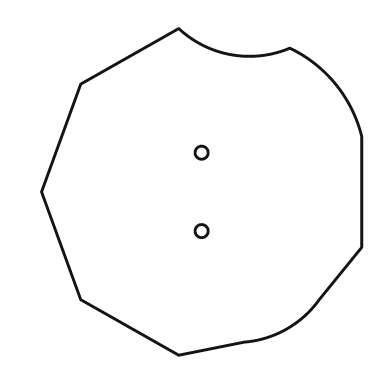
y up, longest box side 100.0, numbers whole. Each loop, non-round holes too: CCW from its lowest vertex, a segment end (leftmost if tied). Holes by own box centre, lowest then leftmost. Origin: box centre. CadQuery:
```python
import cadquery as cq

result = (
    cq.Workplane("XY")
    .moveTo(-7.0, -50.0)
    .lineTo(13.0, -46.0)
    .threePointArc((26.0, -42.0), (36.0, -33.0))
    .lineTo(49.0, -17.0)
    .lineTo(49.0, 17.0)
    .threePointArc((41.0, 33.0), (27.0, 44.0))
    .threePointArc((9.0, 42.0), (-7.0, 50.0))
    .lineTo(-37.0, 33.0)
    .lineTo(-49.0, 0.0)
    .lineTo(-37.0, -33.0)
    .close()
    .moveTo(0.0, -12.0)
    .circle(2.0)
    .moveTo(0.0, 12.0)
    .circle(2.0)
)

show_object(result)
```